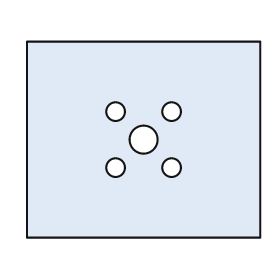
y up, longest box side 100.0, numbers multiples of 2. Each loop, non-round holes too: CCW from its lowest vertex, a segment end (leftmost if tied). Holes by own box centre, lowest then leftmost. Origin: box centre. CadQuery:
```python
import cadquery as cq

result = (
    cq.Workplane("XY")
    .moveTo(-50.0, -42.0)
    .lineTo(50.0, -42.0)
    .lineTo(50.0, 42.0)
    .lineTo(-50.0, 42.0)
    .close()
    .moveTo(-12.0, -12.0)
    .circle(4.0)
    .moveTo(12.0, -12.0)
    .circle(4.0)
    .moveTo(0.0, 0.0)
    .circle(6.0)
    .moveTo(-12.0, 12.0)
    .circle(4.0)
    .moveTo(12.0, 12.0)
    .circle(4.0)
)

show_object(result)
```